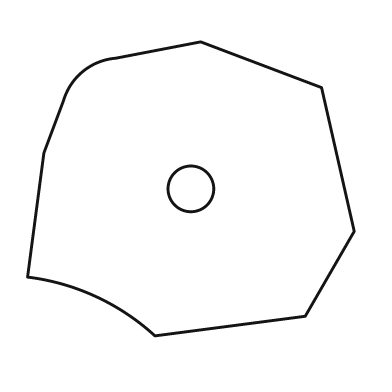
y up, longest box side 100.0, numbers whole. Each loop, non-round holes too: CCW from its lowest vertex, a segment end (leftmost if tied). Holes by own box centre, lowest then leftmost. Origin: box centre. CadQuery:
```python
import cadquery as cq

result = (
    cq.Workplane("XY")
    .moveTo(-11.0, -45.0)
    .lineTo(35.0, -39.0)
    .lineTo(50.0, -13.0)
    .lineTo(40.0, 31.0)
    .lineTo(3.0, 45.0)
    .lineTo(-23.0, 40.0)
    .threePointArc((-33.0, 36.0), (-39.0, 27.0))
    .lineTo(-45.0, 11.0)
    .lineTo(-50.0, -27.0)
    .threePointArc((-29.0, -33.0), (-11.0, -45.0))
    .close()
    .moveTo(0.0, 0.0)
    .circle(7.0)
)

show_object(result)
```